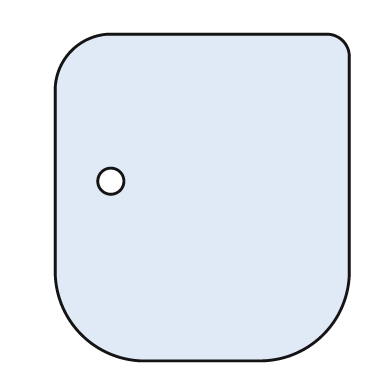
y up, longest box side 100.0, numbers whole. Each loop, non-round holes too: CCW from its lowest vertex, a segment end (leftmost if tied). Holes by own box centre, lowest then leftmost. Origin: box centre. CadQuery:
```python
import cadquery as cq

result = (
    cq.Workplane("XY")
    .moveTo(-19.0, -50.0)
    .lineTo(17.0, -50.0)
    .threePointArc((37.0, -42.0), (45.0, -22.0))
    .lineTo(45.0, 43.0)
    .threePointArc((43.0, 48.0), (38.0, 50.0))
    .lineTo(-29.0, 50.0)
    .threePointArc((-40.0, 45.0), (-45.0, 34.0))
    .lineTo(-45.0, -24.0)
    .threePointArc((-37.0, -42.0), (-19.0, -50.0))
    .close()
    .moveTo(-28.0, 5.0)
    .circle(4.0)
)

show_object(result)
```